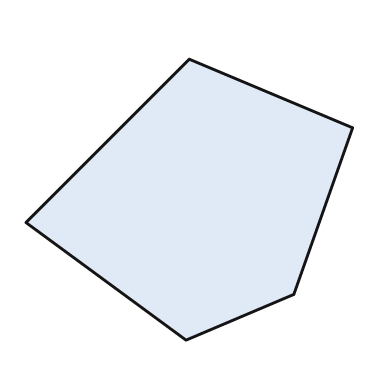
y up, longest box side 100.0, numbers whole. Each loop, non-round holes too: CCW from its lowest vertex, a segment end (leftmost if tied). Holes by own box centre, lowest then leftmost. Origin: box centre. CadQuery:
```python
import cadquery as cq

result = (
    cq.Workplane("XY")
    .moveTo(-1.0, -43.0)
    .lineTo(32.0, -29.0)
    .lineTo(50.0, 22.0)
    .lineTo(0.0, 43.0)
    .lineTo(-50.0, -7.0)
    .close()
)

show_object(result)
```